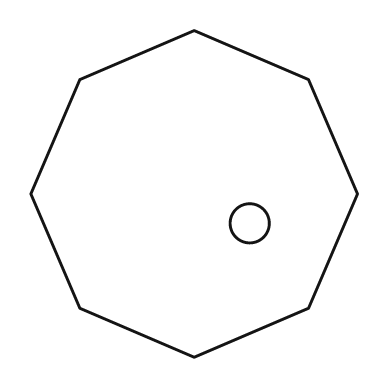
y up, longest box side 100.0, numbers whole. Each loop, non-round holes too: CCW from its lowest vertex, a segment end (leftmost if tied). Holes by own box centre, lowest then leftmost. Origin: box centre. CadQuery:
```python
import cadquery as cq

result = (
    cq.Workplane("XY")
    .moveTo(0.0, -50.0)
    .lineTo(35.0, -35.0)
    .lineTo(50.0, 0.0)
    .lineTo(35.0, 35.0)
    .lineTo(0.0, 50.0)
    .lineTo(-35.0, 35.0)
    .lineTo(-50.0, 0.0)
    .lineTo(-35.0, -35.0)
    .close()
    .moveTo(17.0, -9.0)
    .circle(6.0)
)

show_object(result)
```